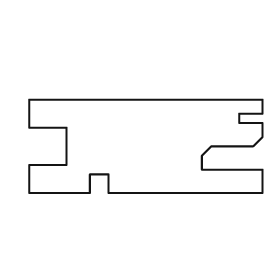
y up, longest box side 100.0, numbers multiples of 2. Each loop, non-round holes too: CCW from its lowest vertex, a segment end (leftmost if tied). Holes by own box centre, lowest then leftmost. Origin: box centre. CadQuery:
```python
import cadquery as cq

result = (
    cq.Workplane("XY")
    .moveTo(-50.0, -20.0)
    .lineTo(-24.0, -20.0)
    .lineTo(-24.0, -12.0)
    .lineTo(-16.0, -12.0)
    .lineTo(-16.0, -20.0)
    .lineTo(50.0, -20.0)
    .lineTo(50.0, -10.0)
    .lineTo(24.0, -10.0)
    .lineTo(24.0, -4.0)
    .lineTo(28.0, 0.0)
    .lineTo(46.0, 0.0)
    .lineTo(50.0, 4.0)
    .lineTo(50.0, 10.0)
    .lineTo(40.0, 10.0)
    .lineTo(40.0, 14.0)
    .lineTo(50.0, 14.0)
    .lineTo(50.0, 20.0)
    .lineTo(-50.0, 20.0)
    .lineTo(-50.0, 8.0)
    .lineTo(-34.0, 8.0)
    .lineTo(-34.0, -8.0)
    .lineTo(-50.0, -8.0)
    .close()
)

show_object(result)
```